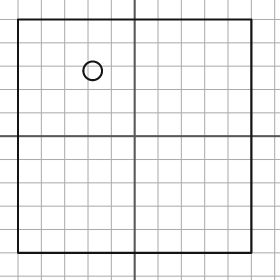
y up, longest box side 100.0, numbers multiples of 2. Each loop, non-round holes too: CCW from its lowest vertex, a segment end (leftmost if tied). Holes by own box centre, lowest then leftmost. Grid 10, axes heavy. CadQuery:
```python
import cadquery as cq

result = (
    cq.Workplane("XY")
    .moveTo(-50.0, -50.0)
    .lineTo(50.0, -50.0)
    .lineTo(50.0, 50.0)
    .lineTo(-50.0, 50.0)
    .close()
    .moveTo(-18.0, 28.0)
    .circle(4.0)
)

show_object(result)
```